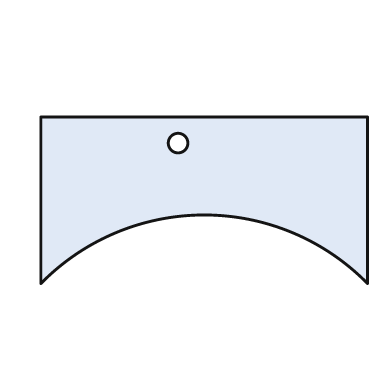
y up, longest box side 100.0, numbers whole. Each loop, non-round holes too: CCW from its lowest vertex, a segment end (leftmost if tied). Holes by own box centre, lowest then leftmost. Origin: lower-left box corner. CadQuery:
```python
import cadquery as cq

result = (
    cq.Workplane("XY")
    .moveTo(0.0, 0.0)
    .threePointArc((50.0, 21.0), (100.0, 0.0))
    .lineTo(100.0, 51.0)
    .lineTo(0.0, 51.0)
    .close()
    .moveTo(42.0, 43.0)
    .circle(3.0)
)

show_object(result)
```